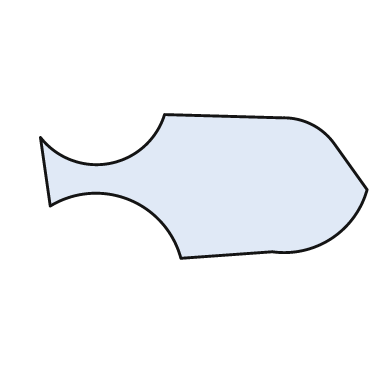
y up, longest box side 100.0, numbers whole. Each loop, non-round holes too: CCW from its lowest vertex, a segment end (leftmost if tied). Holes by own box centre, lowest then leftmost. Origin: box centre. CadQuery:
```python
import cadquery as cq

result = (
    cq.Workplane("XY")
    .moveTo(-7.0, -22.0)
    .lineTo(21.0, -20.0)
    .threePointArc((39.0, -16.0), (50.0, -1.0))
    .lineTo(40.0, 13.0)
    .threePointArc((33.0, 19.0), (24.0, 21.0))
    .lineTo(-12.0, 22.0)
    .threePointArc((-29.0, 7.0), (-50.0, 15.0))
    .lineTo(-47.0, -6.0)
    .threePointArc((-23.0, -4.0), (-7.0, -22.0))
    .close()
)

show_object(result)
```